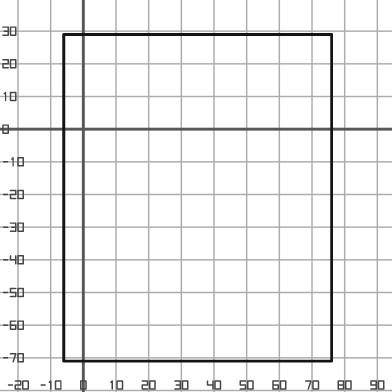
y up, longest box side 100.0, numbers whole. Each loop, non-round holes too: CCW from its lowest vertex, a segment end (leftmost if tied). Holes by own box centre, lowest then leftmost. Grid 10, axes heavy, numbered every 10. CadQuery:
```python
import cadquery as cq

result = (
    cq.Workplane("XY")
    .moveTo(-6.0, -71.0)
    .lineTo(76.0, -71.0)
    .lineTo(76.0, 29.0)
    .lineTo(-6.0, 29.0)
    .close()
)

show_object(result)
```